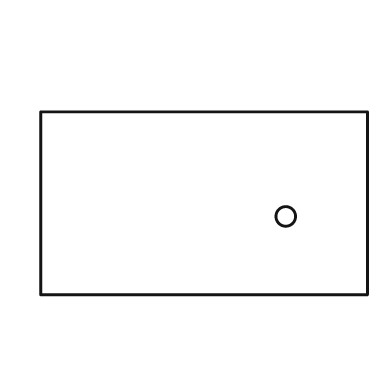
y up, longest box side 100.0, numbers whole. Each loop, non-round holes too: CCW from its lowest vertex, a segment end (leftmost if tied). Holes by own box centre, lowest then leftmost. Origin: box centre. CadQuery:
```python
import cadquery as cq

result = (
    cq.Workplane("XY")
    .moveTo(-50.0, -28.0)
    .lineTo(50.0, -28.0)
    .lineTo(50.0, 28.0)
    .lineTo(-50.0, 28.0)
    .close()
    .moveTo(25.0, -4.0)
    .circle(3.0)
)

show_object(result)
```